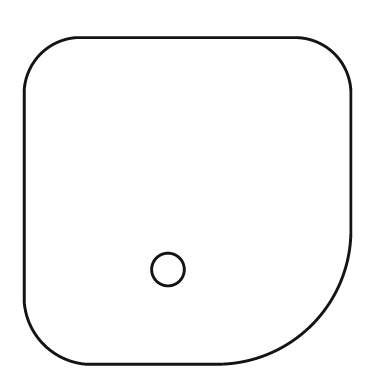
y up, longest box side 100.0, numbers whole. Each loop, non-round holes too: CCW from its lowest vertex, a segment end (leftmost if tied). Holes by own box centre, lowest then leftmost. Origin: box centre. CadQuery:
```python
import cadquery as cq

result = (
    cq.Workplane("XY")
    .moveTo(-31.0, -50.0)
    .lineTo(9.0, -50.0)
    .threePointArc((38.0, -38.0), (50.0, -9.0))
    .lineTo(50.0, 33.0)
    .threePointArc((45.0, 45.0), (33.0, 50.0))
    .lineTo(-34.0, 50.0)
    .threePointArc((-45.0, 45.0), (-50.0, 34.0))
    .lineTo(-50.0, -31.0)
    .threePointArc((-44.0, -44.0), (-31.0, -50.0))
    .close()
    .moveTo(-6.0, -21.0)
    .circle(5.0)
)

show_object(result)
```